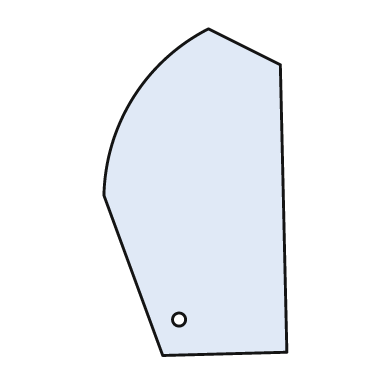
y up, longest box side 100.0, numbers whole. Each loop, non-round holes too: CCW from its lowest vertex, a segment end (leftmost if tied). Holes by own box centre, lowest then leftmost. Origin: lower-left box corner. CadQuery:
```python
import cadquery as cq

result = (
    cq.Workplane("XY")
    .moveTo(18.0, 0.0)
    .lineTo(56.0, 1.0)
    .lineTo(54.0, 89.0)
    .lineTo(32.0, 100.0)
    .threePointArc((9.0, 79.0), (0.0, 49.0))
    .close()
    .moveTo(23.0, 11.0)
    .circle(2.0)
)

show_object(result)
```